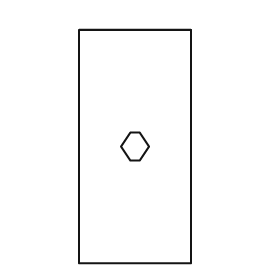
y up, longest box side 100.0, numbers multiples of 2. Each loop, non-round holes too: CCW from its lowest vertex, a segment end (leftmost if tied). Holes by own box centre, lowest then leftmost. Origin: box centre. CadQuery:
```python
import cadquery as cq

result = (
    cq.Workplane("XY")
    .moveTo(-24.0, -50.0)
    .lineTo(24.0, -50.0)
    .lineTo(24.0, 50.0)
    .lineTo(-24.0, 50.0)
    .close()
    .moveTo(-2.0, -6.0)
    .lineTo(2.0, -6.0)
    .lineTo(6.0, 0.0)
    .lineTo(2.0, 6.0)
    .lineTo(-2.0, 6.0)
    .lineTo(-6.0, 0.0)
    .close()
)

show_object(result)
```